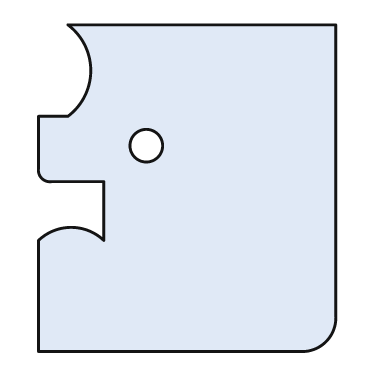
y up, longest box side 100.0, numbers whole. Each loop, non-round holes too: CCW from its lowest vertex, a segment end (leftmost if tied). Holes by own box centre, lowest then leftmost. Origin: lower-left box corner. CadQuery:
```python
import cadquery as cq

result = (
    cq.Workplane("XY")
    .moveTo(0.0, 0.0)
    .lineTo(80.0, 0.0)
    .threePointArc((88.0, 3.0), (91.0, 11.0))
    .lineTo(91.0, 100.0)
    .lineTo(9.0, 100.0)
    .threePointArc((16.0, 86.0), (9.0, 72.0))
    .lineTo(0.0, 72.0)
    .lineTo(0.0, 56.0)
    .threePointArc((1.0, 53.0), (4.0, 52.0))
    .lineTo(20.0, 52.0)
    .lineTo(20.0, 34.0)
    .threePointArc((10.0, 38.0), (0.0, 34.0))
    .close()
    .moveTo(33.0, 63.0)
    .circle(5.0)
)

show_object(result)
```